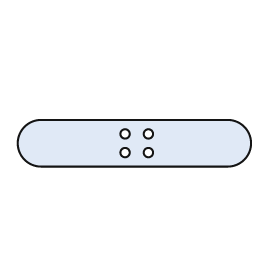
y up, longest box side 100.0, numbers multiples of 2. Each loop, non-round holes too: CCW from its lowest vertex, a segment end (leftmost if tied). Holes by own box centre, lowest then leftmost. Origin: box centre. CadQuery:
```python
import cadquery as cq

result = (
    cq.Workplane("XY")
    .moveTo(-40.0, -10.0)
    .lineTo(40.0, -10.0)
    .threePointArc((50.0, 0.0), (40.0, 10.0))
    .lineTo(-40.0, 10.0)
    .threePointArc((-50.0, 0.0), (-40.0, -10.0))
    .close()
    .moveTo(-4.0, -4.0)
    .circle(2.0)
    .moveTo(6.0, -4.0)
    .circle(2.0)
    .moveTo(-4.0, 4.0)
    .circle(2.0)
    .moveTo(6.0, 4.0)
    .circle(2.0)
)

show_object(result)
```